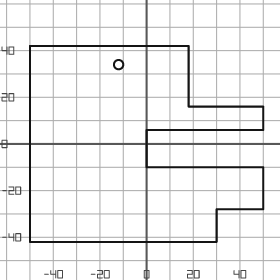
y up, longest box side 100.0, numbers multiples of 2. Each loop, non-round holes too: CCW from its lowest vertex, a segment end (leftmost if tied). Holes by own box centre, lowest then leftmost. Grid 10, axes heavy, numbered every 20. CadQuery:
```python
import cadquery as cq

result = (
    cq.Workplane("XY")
    .moveTo(-50.0, -42.0)
    .lineTo(30.0, -42.0)
    .lineTo(30.0, -28.0)
    .lineTo(50.0, -28.0)
    .lineTo(50.0, -10.0)
    .lineTo(0.0, -10.0)
    .lineTo(0.0, 6.0)
    .lineTo(50.0, 6.0)
    .lineTo(50.0, 16.0)
    .lineTo(18.0, 16.0)
    .lineTo(18.0, 42.0)
    .lineTo(-50.0, 42.0)
    .close()
    .moveTo(-12.0, 34.0)
    .circle(2.0)
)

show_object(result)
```